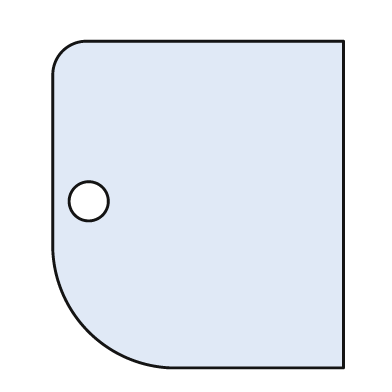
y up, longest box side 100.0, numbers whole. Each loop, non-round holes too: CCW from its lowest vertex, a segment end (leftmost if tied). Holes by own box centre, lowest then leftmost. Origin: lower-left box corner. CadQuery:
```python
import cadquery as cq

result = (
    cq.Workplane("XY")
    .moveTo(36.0, 0.0)
    .lineTo(89.0, 0.0)
    .lineTo(89.0, 100.0)
    .lineTo(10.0, 100.0)
    .threePointArc((3.0, 97.0), (0.0, 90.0))
    .lineTo(0.0, 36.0)
    .threePointArc((11.0, 11.0), (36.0, 0.0))
    .close()
    .moveTo(11.0, 51.0)
    .circle(6.0)
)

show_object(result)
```